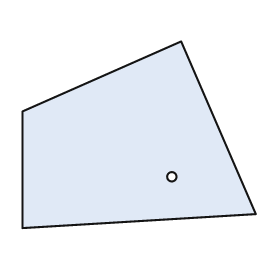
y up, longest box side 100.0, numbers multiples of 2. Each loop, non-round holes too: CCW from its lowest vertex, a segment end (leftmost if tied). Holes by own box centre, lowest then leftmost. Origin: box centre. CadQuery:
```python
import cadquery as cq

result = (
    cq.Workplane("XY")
    .moveTo(-50.0, -40.0)
    .lineTo(50.0, -34.0)
    .lineTo(18.0, 40.0)
    .lineTo(-50.0, 10.0)
    .close()
    .moveTo(14.0, -18.0)
    .circle(2.0)
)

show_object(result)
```